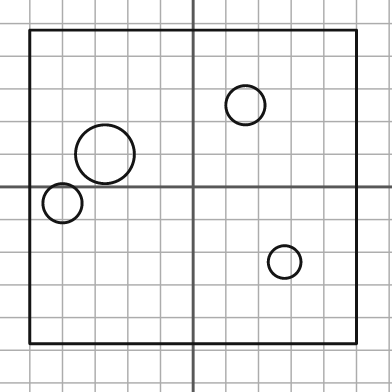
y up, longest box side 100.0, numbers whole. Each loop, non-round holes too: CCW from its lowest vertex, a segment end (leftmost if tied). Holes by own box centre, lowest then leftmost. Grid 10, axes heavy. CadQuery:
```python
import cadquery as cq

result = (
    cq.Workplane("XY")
    .moveTo(-50.0, -48.0)
    .lineTo(50.0, -48.0)
    .lineTo(50.0, 48.0)
    .lineTo(-50.0, 48.0)
    .close()
    .moveTo(28.0, -23.0)
    .circle(5.0)
    .moveTo(-40.0, -5.0)
    .circle(6.0)
    .moveTo(-27.0, 10.0)
    .circle(9.0)
    .moveTo(16.0, 25.0)
    .circle(6.0)
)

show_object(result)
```